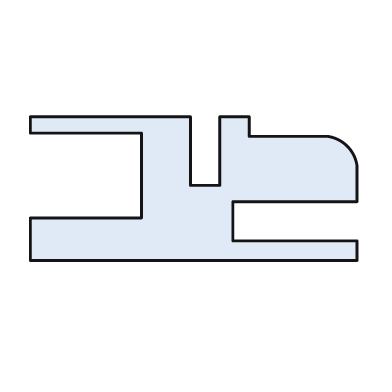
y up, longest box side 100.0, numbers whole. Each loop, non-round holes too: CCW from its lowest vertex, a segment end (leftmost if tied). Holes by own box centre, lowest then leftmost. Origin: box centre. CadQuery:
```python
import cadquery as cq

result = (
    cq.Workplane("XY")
    .moveTo(-50.0, -22.0)
    .lineTo(50.0, -22.0)
    .lineTo(50.0, -16.0)
    .lineTo(12.0, -16.0)
    .lineTo(12.0, -4.0)
    .lineTo(50.0, -4.0)
    .lineTo(50.0, 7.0)
    .threePointArc((47.0, 13.0), (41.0, 16.0))
    .lineTo(17.0, 16.0)
    .lineTo(17.0, 22.0)
    .lineTo(8.0, 22.0)
    .lineTo(8.0, 1.0)
    .lineTo(-1.0, 1.0)
    .lineTo(-1.0, 22.0)
    .lineTo(-50.0, 22.0)
    .lineTo(-50.0, 17.0)
    .lineTo(-16.0, 17.0)
    .lineTo(-16.0, -9.0)
    .lineTo(-50.0, -9.0)
    .close()
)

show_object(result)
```